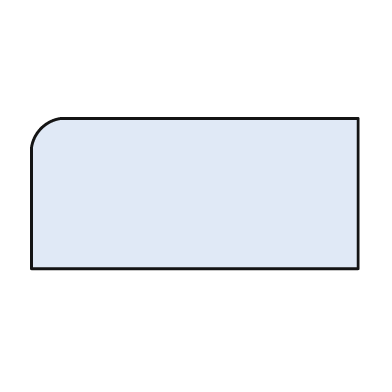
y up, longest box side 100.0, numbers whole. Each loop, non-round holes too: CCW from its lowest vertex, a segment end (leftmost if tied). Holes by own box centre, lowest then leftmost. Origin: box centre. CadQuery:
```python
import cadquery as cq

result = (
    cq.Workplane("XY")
    .moveTo(-50.0, -23.0)
    .lineTo(50.0, -23.0)
    .lineTo(50.0, 23.0)
    .lineTo(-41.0, 23.0)
    .threePointArc((-47.0, 20.0), (-50.0, 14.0))
    .close()
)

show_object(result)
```